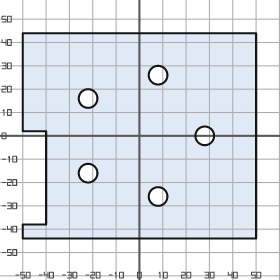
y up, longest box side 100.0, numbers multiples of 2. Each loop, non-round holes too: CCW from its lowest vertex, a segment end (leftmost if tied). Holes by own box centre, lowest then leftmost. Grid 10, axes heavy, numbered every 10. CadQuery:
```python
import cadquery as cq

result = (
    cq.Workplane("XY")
    .moveTo(-50.0, -44.0)
    .lineTo(50.0, -44.0)
    .lineTo(50.0, 44.0)
    .lineTo(-50.0, 44.0)
    .lineTo(-50.0, 2.0)
    .lineTo(-40.0, 2.0)
    .lineTo(-40.0, -38.0)
    .lineTo(-50.0, -38.0)
    .close()
    .moveTo(8.0, -26.0)
    .circle(4.0)
    .moveTo(-22.0, -16.0)
    .circle(4.0)
    .moveTo(28.0, 0.0)
    .circle(4.0)
    .moveTo(-22.0, 16.0)
    .circle(4.0)
    .moveTo(8.0, 26.0)
    .circle(4.0)
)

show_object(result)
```